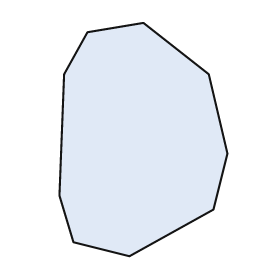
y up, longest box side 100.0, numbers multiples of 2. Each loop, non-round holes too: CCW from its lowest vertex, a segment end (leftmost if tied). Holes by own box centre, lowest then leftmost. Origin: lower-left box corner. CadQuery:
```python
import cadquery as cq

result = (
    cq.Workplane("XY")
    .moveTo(30.0, 0.0)
    .lineTo(66.0, 20.0)
    .lineTo(72.0, 44.0)
    .lineTo(64.0, 78.0)
    .lineTo(36.0, 100.0)
    .lineTo(12.0, 96.0)
    .lineTo(2.0, 78.0)
    .lineTo(0.0, 26.0)
    .lineTo(6.0, 6.0)
    .close()
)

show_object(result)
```